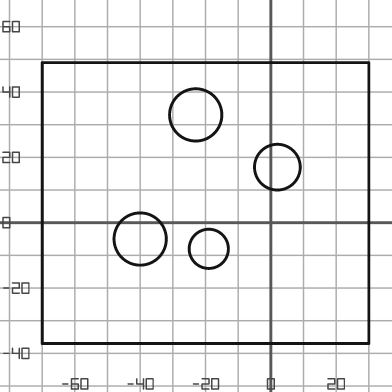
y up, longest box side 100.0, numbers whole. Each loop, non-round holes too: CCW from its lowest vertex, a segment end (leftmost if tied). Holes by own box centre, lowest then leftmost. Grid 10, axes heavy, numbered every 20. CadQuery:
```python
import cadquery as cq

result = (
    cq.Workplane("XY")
    .moveTo(-70.0, -37.0)
    .lineTo(30.0, -37.0)
    .lineTo(30.0, 49.0)
    .lineTo(-70.0, 49.0)
    .close()
    .moveTo(-19.0, -8.0)
    .circle(6.0)
    .moveTo(-40.0, -5.0)
    .circle(8.0)
    .moveTo(2.0, 17.0)
    .circle(7.0)
    .moveTo(-23.0, 33.0)
    .circle(8.0)
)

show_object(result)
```